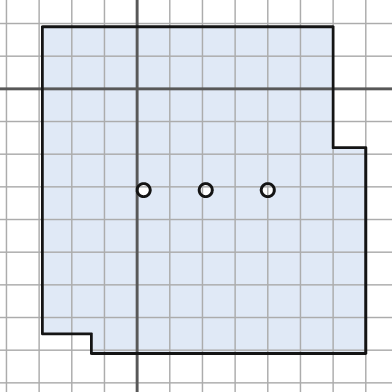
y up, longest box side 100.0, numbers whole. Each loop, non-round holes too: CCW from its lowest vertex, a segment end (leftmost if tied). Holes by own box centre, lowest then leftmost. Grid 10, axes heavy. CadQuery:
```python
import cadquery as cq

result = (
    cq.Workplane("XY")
    .moveTo(-14.0, -81.0)
    .lineTo(70.0, -81.0)
    .lineTo(70.0, -18.0)
    .lineTo(60.0, -18.0)
    .lineTo(60.0, 19.0)
    .lineTo(-29.0, 19.0)
    .lineTo(-29.0, -75.0)
    .lineTo(-14.0, -75.0)
    .close()
    .moveTo(2.0, -31.0)
    .circle(2.0)
    .moveTo(21.0, -31.0)
    .circle(2.0)
    .moveTo(40.0, -31.0)
    .circle(2.0)
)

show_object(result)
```